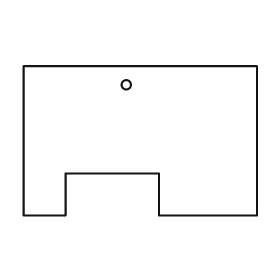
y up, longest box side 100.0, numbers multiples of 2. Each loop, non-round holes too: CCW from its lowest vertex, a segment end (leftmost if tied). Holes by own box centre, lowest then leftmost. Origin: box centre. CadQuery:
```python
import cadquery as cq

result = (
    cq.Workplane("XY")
    .moveTo(-50.0, -32.0)
    .lineTo(-32.0, -32.0)
    .lineTo(-32.0, -14.0)
    .lineTo(8.0, -14.0)
    .lineTo(8.0, -32.0)
    .lineTo(50.0, -32.0)
    .lineTo(50.0, 32.0)
    .lineTo(-50.0, 32.0)
    .close()
    .moveTo(-6.0, 24.0)
    .circle(2.0)
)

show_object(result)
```